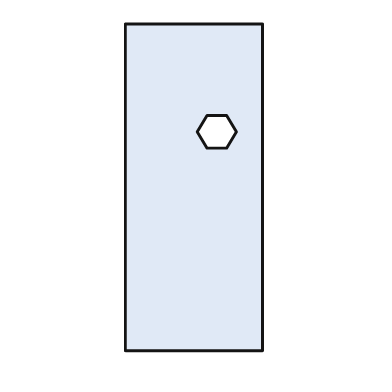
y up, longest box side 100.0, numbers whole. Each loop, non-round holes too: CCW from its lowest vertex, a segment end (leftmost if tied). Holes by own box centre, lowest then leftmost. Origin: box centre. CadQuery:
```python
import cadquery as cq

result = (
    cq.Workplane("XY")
    .moveTo(-21.0, -50.0)
    .lineTo(21.0, -50.0)
    .lineTo(21.0, 50.0)
    .lineTo(-21.0, 50.0)
    .close()
    .moveTo(4.0, 12.0)
    .lineTo(10.0, 12.0)
    .lineTo(13.0, 17.0)
    .lineTo(10.0, 22.0)
    .lineTo(4.0, 22.0)
    .lineTo(1.0, 17.0)
    .close()
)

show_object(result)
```